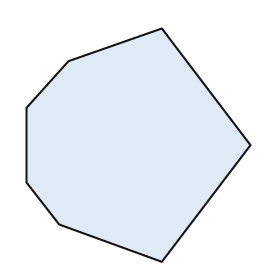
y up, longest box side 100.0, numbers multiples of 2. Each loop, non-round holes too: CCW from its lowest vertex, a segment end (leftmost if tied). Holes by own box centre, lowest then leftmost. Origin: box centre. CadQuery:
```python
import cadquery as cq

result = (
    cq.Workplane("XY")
    .moveTo(10.0, -50.0)
    .lineTo(48.0, 0.0)
    .lineTo(10.0, 50.0)
    .lineTo(-30.0, 36.0)
    .lineTo(-48.0, 16.0)
    .lineTo(-48.0, -16.0)
    .lineTo(-34.0, -34.0)
    .close()
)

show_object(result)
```